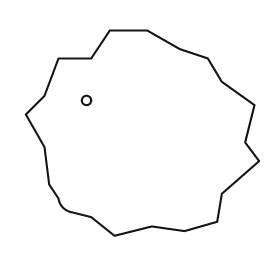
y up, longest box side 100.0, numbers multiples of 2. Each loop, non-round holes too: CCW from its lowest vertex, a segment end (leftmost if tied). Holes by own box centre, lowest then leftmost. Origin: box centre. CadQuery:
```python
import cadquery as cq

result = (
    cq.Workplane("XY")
    .moveTo(-12.0, -44.0)
    .lineTo(4.0, -40.0)
    .lineTo(18.0, -42.0)
    .lineTo(32.0, -38.0)
    .lineTo(34.0, -26.0)
    .lineTo(50.0, -12.0)
    .lineTo(44.0, -4.0)
    .lineTo(48.0, 12.0)
    .lineTo(34.0, 22.0)
    .lineTo(28.0, 32.0)
    .lineTo(16.0, 36.0)
    .lineTo(2.0, 44.0)
    .lineTo(-14.0, 44.0)
    .lineTo(-22.0, 32.0)
    .lineTo(-36.0, 32.0)
    .lineTo(-42.0, 16.0)
    .lineTo(-50.0, 8.0)
    .lineTo(-42.0, -6.0)
    .lineTo(-40.0, -22.0)
    .lineTo(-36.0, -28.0)
    .threePointArc((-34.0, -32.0), (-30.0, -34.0))
    .lineTo(-22.0, -36.0)
    .close()
    .moveTo(-24.0, 14.0)
    .circle(2.0)
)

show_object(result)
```